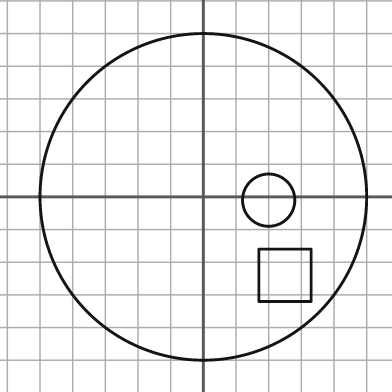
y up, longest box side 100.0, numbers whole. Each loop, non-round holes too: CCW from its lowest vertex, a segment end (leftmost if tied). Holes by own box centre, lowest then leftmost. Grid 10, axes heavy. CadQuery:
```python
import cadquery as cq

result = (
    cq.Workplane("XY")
    .moveTo(0.0, 0.0)
    .circle(50.0)
    .moveTo(17.0, -32.0)
    .lineTo(33.0, -32.0)
    .lineTo(33.0, -16.0)
    .lineTo(17.0, -16.0)
    .close()
    .moveTo(20.0, -1.0)
    .circle(8.0)
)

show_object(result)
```